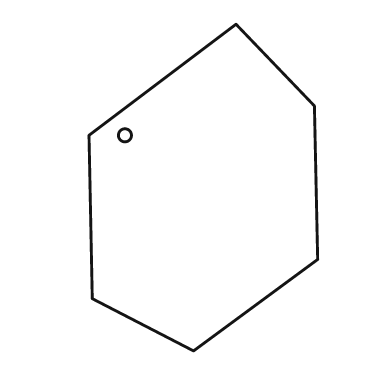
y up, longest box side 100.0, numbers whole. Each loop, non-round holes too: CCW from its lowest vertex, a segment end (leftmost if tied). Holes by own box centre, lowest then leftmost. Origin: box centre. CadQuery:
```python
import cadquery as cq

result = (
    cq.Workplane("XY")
    .moveTo(-3.0, -50.0)
    .lineTo(35.0, -22.0)
    .lineTo(34.0, 25.0)
    .lineTo(10.0, 50.0)
    .lineTo(-35.0, 16.0)
    .lineTo(-34.0, -34.0)
    .close()
    .moveTo(-24.0, 16.0)
    .circle(2.0)
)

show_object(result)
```